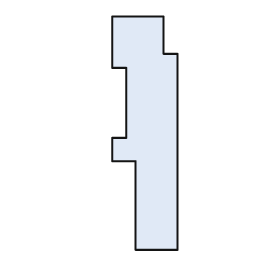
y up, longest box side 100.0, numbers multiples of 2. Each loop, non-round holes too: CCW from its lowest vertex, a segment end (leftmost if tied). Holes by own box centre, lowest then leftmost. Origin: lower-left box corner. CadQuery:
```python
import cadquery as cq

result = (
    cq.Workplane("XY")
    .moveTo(10.0, 0.0)
    .lineTo(28.0, 0.0)
    .lineTo(28.0, 84.0)
    .lineTo(22.0, 84.0)
    .lineTo(22.0, 100.0)
    .lineTo(0.0, 100.0)
    .lineTo(0.0, 78.0)
    .lineTo(6.0, 78.0)
    .lineTo(6.0, 48.0)
    .lineTo(0.0, 48.0)
    .lineTo(0.0, 38.0)
    .lineTo(10.0, 38.0)
    .close()
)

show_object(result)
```